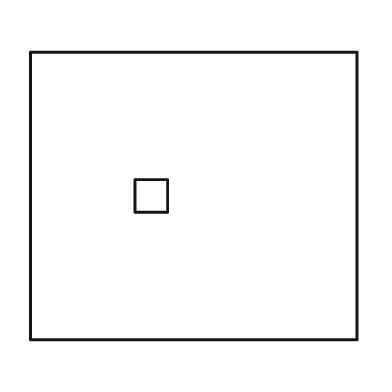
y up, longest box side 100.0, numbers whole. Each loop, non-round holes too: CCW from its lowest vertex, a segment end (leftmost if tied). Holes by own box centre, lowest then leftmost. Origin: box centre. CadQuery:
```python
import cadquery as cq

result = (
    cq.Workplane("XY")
    .moveTo(-50.0, -44.0)
    .lineTo(50.0, -44.0)
    .lineTo(50.0, 44.0)
    .lineTo(-50.0, 44.0)
    .close()
    .moveTo(-18.0, -5.0)
    .lineTo(-8.0, -5.0)
    .lineTo(-8.0, 5.0)
    .lineTo(-18.0, 5.0)
    .close()
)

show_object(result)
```